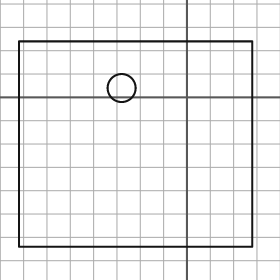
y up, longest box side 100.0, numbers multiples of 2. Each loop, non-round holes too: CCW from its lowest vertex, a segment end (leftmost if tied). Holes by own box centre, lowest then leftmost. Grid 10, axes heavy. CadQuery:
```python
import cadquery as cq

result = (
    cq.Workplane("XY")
    .moveTo(-72.0, -64.0)
    .lineTo(28.0, -64.0)
    .lineTo(28.0, 24.0)
    .lineTo(-72.0, 24.0)
    .close()
    .moveTo(-28.0, 4.0)
    .circle(6.0)
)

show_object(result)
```